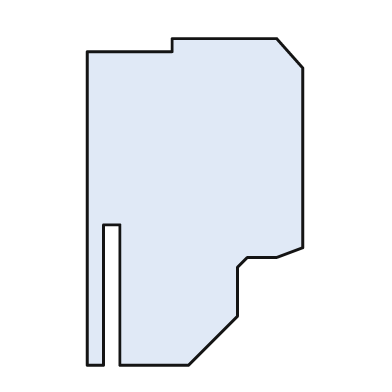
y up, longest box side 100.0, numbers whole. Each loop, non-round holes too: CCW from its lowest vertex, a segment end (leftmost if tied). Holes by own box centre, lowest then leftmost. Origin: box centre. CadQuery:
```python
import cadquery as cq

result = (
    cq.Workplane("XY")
    .moveTo(-33.0, -50.0)
    .lineTo(-28.0, -50.0)
    .lineTo(-28.0, -7.0)
    .lineTo(-23.0, -7.0)
    .lineTo(-23.0, -50.0)
    .lineTo(-2.0, -50.0)
    .lineTo(13.0, -35.0)
    .lineTo(13.0, -20.0)
    .lineTo(16.0, -17.0)
    .lineTo(25.0, -17.0)
    .lineTo(33.0, -14.0)
    .lineTo(33.0, 41.0)
    .lineTo(25.0, 50.0)
    .lineTo(-7.0, 50.0)
    .lineTo(-7.0, 46.0)
    .lineTo(-33.0, 46.0)
    .close()
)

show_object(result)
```